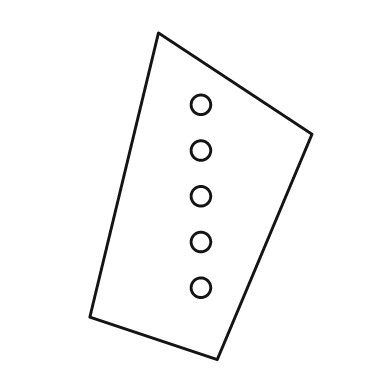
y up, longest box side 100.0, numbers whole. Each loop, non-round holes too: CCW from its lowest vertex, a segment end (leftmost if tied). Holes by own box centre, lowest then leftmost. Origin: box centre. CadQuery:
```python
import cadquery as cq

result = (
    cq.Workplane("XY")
    .moveTo(5.0, -50.0)
    .lineTo(34.0, 19.0)
    .lineTo(-13.0, 50.0)
    .lineTo(-34.0, -37.0)
    .close()
    .moveTo(0.0, -28.0)
    .circle(3.0)
    .moveTo(0.0, -14.0)
    .circle(3.0)
    .moveTo(0.0, 0.0)
    .circle(3.0)
    .moveTo(0.0, 14.0)
    .circle(3.0)
    .moveTo(0.0, 28.0)
    .circle(3.0)
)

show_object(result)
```